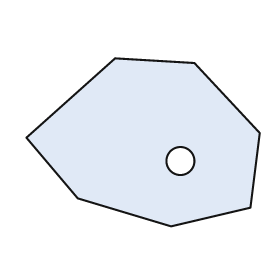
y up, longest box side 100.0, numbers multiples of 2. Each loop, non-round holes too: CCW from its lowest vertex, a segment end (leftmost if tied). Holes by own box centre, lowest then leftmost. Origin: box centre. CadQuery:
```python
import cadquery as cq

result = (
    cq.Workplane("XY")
    .moveTo(12.0, -36.0)
    .lineTo(46.0, -28.0)
    .lineTo(50.0, 4.0)
    .lineTo(22.0, 34.0)
    .lineTo(-12.0, 36.0)
    .lineTo(-50.0, 2.0)
    .lineTo(-28.0, -24.0)
    .close()
    .moveTo(16.0, -8.0)
    .circle(6.0)
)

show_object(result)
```